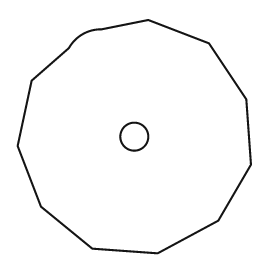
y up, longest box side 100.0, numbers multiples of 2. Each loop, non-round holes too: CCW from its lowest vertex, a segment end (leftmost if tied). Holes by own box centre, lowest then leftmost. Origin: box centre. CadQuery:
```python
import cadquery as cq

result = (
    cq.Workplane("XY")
    .moveTo(10.0, -50.0)
    .lineTo(36.0, -36.0)
    .lineTo(50.0, -12.0)
    .lineTo(48.0, 16.0)
    .lineTo(32.0, 40.0)
    .lineTo(6.0, 50.0)
    .lineTo(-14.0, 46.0)
    .threePointArc((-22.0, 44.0), (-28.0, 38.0))
    .lineTo(-44.0, 24.0)
    .lineTo(-50.0, -4.0)
    .lineTo(-40.0, -30.0)
    .lineTo(-18.0, -48.0)
    .close()
    .moveTo(0.0, 0.0)
    .circle(6.0)
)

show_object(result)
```